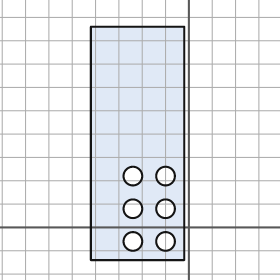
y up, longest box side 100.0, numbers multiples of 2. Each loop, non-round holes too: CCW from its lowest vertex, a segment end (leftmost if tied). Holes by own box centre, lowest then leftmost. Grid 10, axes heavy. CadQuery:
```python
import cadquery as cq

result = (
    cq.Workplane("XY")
    .moveTo(-42.0, -14.0)
    .lineTo(-2.0, -14.0)
    .lineTo(-2.0, 86.0)
    .lineTo(-42.0, 86.0)
    .close()
    .moveTo(-24.0, -6.0)
    .circle(4.0)
    .moveTo(-10.0, -6.0)
    .circle(4.0)
    .moveTo(-24.0, 8.0)
    .circle(4.0)
    .moveTo(-10.0, 8.0)
    .circle(4.0)
    .moveTo(-24.0, 22.0)
    .circle(4.0)
    .moveTo(-10.0, 22.0)
    .circle(4.0)
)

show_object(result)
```